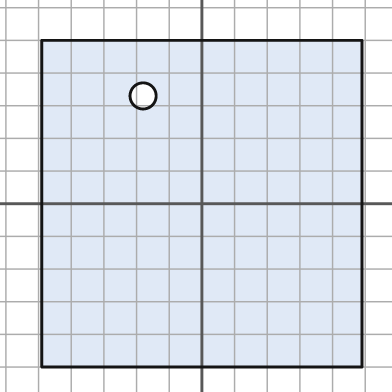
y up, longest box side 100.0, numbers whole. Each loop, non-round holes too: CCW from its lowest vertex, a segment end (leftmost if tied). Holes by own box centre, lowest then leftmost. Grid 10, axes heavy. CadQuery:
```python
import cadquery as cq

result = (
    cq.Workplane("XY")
    .moveTo(-49.0, -50.0)
    .lineTo(49.0, -50.0)
    .lineTo(49.0, 50.0)
    .lineTo(-49.0, 50.0)
    .close()
    .moveTo(-18.0, 33.0)
    .circle(4.0)
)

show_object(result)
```